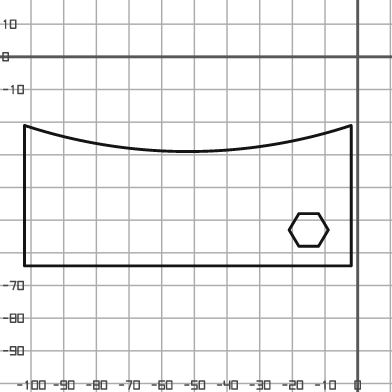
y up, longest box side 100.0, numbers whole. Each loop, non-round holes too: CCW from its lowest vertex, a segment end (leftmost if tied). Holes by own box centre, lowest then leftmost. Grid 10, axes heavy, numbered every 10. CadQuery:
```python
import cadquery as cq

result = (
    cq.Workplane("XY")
    .moveTo(-102.0, -64.0)
    .lineTo(-2.0, -64.0)
    .lineTo(-2.0, -21.0)
    .threePointArc((-52.0, -29.0), (-102.0, -21.0))
    .close()
    .moveTo(-18.0, -58.0)
    .lineTo(-12.0, -58.0)
    .lineTo(-9.0, -53.0)
    .lineTo(-12.0, -48.0)
    .lineTo(-18.0, -48.0)
    .lineTo(-21.0, -53.0)
    .close()
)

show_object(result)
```